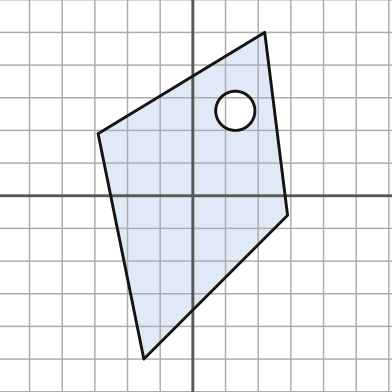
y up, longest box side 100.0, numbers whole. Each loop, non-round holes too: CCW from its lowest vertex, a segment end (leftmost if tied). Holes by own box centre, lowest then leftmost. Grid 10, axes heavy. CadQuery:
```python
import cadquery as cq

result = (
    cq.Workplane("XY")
    .moveTo(-15.0, -50.0)
    .lineTo(29.0, -6.0)
    .lineTo(22.0, 50.0)
    .lineTo(-29.0, 19.0)
    .close()
    .moveTo(13.0, 26.0)
    .circle(6.0)
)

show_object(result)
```